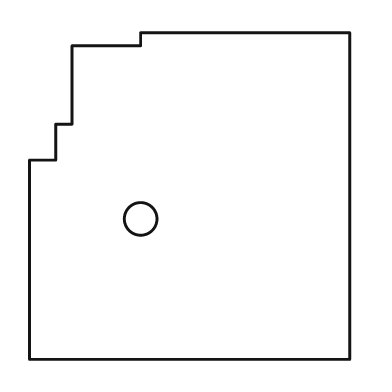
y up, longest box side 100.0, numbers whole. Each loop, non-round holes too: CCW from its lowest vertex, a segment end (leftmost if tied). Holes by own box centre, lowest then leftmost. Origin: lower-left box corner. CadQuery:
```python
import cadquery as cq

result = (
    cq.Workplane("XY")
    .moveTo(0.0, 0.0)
    .lineTo(98.0, 0.0)
    .lineTo(98.0, 100.0)
    .lineTo(34.0, 100.0)
    .lineTo(34.0, 96.0)
    .lineTo(13.0, 96.0)
    .lineTo(13.0, 72.0)
    .lineTo(8.0, 72.0)
    .lineTo(8.0, 61.0)
    .lineTo(0.0, 61.0)
    .close()
    .moveTo(34.0, 43.0)
    .circle(5.0)
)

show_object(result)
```